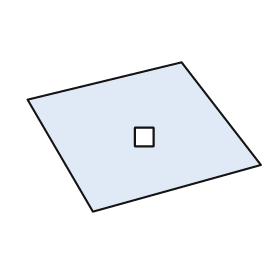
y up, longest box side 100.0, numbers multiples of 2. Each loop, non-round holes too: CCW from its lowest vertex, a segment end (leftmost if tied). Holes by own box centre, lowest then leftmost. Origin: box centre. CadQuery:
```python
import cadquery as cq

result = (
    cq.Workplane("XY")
    .moveTo(-22.0, -32.0)
    .lineTo(50.0, -12.0)
    .lineTo(16.0, 32.0)
    .lineTo(-50.0, 16.0)
    .close()
    .moveTo(-4.0, -4.0)
    .lineTo(4.0, -4.0)
    .lineTo(4.0, 4.0)
    .lineTo(-4.0, 4.0)
    .close()
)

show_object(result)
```